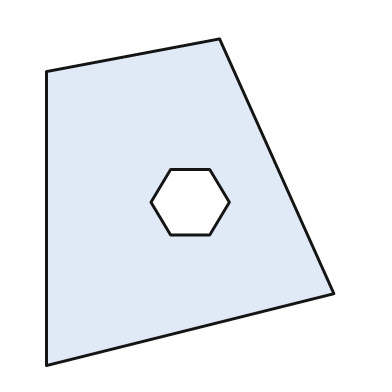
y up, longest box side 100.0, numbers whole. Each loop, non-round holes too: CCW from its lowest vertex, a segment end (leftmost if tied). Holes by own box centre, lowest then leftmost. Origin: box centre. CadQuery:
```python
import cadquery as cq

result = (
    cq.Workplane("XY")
    .moveTo(-44.0, -50.0)
    .lineTo(44.0, -28.0)
    .lineTo(9.0, 50.0)
    .lineTo(-44.0, 40.0)
    .close()
    .moveTo(-6.0, -10.0)
    .lineTo(6.0, -10.0)
    .lineTo(12.0, 0.0)
    .lineTo(6.0, 10.0)
    .lineTo(-6.0, 10.0)
    .lineTo(-12.0, 0.0)
    .close()
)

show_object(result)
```